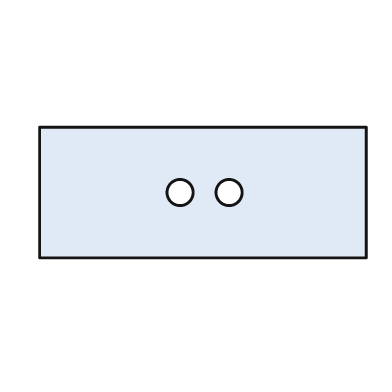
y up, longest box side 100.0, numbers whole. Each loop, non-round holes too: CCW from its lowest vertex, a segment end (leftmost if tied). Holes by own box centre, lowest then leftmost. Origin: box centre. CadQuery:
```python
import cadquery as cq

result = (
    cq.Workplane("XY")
    .moveTo(-50.0, -20.0)
    .lineTo(50.0, -20.0)
    .lineTo(50.0, 20.0)
    .lineTo(-50.0, 20.0)
    .close()
    .moveTo(-7.0, 0.0)
    .circle(4.0)
    .moveTo(8.0, 0.0)
    .circle(4.0)
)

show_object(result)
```